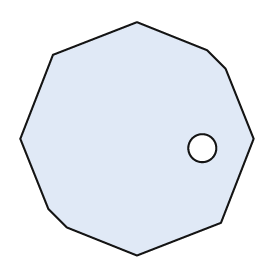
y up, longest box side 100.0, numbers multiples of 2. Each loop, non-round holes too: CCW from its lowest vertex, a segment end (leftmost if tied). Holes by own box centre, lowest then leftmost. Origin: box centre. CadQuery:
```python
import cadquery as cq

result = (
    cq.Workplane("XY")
    .moveTo(0.0, -50.0)
    .lineTo(36.0, -36.0)
    .lineTo(50.0, 0.0)
    .lineTo(38.0, 30.0)
    .lineTo(30.0, 38.0)
    .lineTo(0.0, 50.0)
    .lineTo(-36.0, 36.0)
    .lineTo(-50.0, 0.0)
    .lineTo(-38.0, -30.0)
    .lineTo(-30.0, -38.0)
    .close()
    .moveTo(28.0, -4.0)
    .circle(6.0)
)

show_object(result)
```